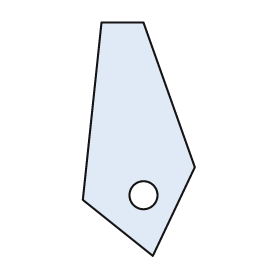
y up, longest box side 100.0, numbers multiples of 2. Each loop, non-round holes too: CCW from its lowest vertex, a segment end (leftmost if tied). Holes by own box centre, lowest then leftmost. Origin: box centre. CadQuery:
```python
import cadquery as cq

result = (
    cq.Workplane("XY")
    .moveTo(6.0, -50.0)
    .lineTo(24.0, -12.0)
    .lineTo(2.0, 50.0)
    .lineTo(-16.0, 50.0)
    .lineTo(-24.0, -26.0)
    .close()
    .moveTo(2.0, -24.0)
    .circle(6.0)
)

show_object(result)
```